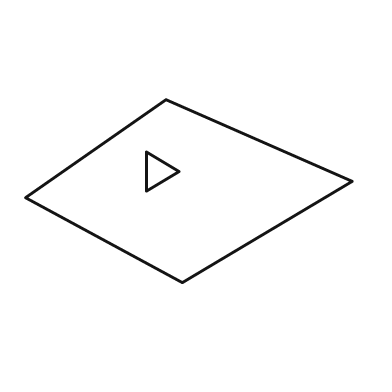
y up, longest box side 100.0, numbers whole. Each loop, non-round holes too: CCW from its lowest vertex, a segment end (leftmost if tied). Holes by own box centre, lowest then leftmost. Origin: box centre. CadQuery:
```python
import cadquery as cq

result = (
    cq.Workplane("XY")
    .moveTo(-2.0, -28.0)
    .lineTo(50.0, 3.0)
    .lineTo(-7.0, 28.0)
    .lineTo(-50.0, -2.0)
    .close()
    .moveTo(-13.0, 0.0)
    .lineTo(-3.0, 6.0)
    .lineTo(-13.0, 12.0)
    .close()
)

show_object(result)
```